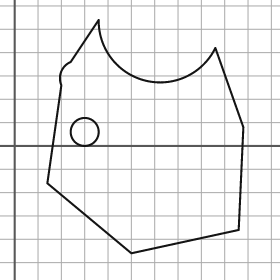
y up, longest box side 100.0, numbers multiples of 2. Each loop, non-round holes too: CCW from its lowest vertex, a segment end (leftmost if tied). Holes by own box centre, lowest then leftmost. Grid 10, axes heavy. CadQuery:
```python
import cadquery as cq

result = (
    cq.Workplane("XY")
    .moveTo(50.0, -46.0)
    .lineTo(96.0, -36.0)
    .lineTo(98.0, 8.0)
    .lineTo(86.0, 42.0)
    .threePointArc((56.0, 28.0), (36.0, 54.0))
    .lineTo(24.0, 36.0)
    .threePointArc((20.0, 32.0), (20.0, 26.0))
    .lineTo(14.0, -16.0)
    .close()
    .moveTo(30.0, 6.0)
    .circle(6.0)
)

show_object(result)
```